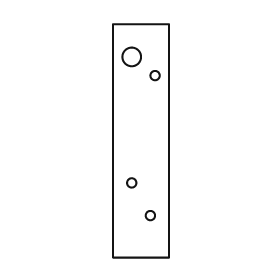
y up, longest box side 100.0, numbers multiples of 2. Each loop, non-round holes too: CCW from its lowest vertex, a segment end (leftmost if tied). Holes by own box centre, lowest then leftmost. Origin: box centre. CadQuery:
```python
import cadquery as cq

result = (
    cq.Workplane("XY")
    .moveTo(-12.0, -50.0)
    .lineTo(12.0, -50.0)
    .lineTo(12.0, 50.0)
    .lineTo(-12.0, 50.0)
    .close()
    .moveTo(4.0, -32.0)
    .circle(2.0)
    .moveTo(-4.0, -18.0)
    .circle(2.0)
    .moveTo(6.0, 28.0)
    .circle(2.0)
    .moveTo(-4.0, 36.0)
    .circle(4.0)
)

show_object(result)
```